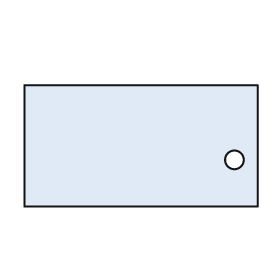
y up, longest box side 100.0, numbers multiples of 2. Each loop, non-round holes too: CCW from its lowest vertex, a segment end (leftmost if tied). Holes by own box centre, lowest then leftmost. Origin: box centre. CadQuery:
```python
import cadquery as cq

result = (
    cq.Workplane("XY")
    .moveTo(-50.0, -26.0)
    .lineTo(50.0, -26.0)
    .lineTo(50.0, 26.0)
    .lineTo(-50.0, 26.0)
    .close()
    .moveTo(40.0, -6.0)
    .circle(4.0)
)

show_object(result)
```